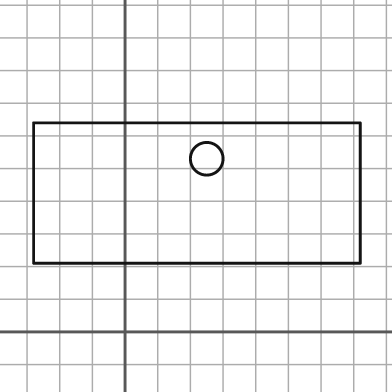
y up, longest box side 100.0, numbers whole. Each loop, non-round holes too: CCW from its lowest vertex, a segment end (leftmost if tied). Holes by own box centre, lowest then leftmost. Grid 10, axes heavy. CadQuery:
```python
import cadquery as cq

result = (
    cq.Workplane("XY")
    .moveTo(-28.0, 21.0)
    .lineTo(72.0, 21.0)
    .lineTo(72.0, 64.0)
    .lineTo(-28.0, 64.0)
    .close()
    .moveTo(25.0, 53.0)
    .circle(5.0)
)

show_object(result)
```